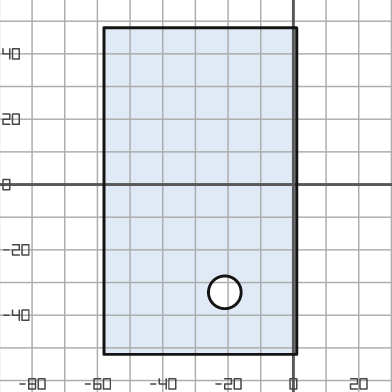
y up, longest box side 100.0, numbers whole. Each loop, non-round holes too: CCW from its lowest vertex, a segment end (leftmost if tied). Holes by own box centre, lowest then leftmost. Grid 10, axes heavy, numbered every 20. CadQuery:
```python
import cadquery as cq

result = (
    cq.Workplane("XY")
    .moveTo(-58.0, -52.0)
    .lineTo(1.0, -52.0)
    .lineTo(1.0, 48.0)
    .lineTo(-58.0, 48.0)
    .close()
    .moveTo(-21.0, -33.0)
    .circle(5.0)
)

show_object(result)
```